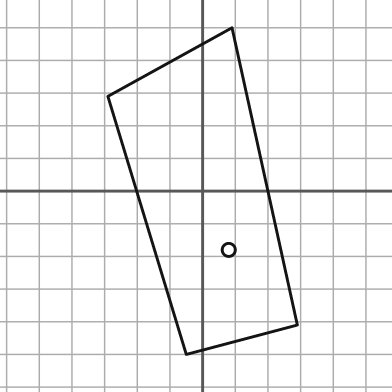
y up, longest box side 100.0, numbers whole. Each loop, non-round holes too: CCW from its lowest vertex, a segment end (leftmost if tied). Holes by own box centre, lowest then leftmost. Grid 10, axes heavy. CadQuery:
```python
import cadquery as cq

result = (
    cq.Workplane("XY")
    .moveTo(-5.0, -50.0)
    .lineTo(29.0, -41.0)
    .lineTo(9.0, 50.0)
    .lineTo(-29.0, 29.0)
    .close()
    .moveTo(8.0, -18.0)
    .circle(2.0)
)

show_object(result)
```